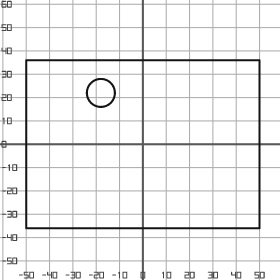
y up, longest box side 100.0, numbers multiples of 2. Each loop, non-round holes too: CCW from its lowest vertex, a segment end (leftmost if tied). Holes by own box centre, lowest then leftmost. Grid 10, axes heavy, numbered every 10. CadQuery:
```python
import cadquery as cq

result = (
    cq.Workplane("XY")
    .moveTo(-50.0, -36.0)
    .lineTo(50.0, -36.0)
    .lineTo(50.0, 36.0)
    .lineTo(-50.0, 36.0)
    .close()
    .moveTo(-18.0, 22.0)
    .circle(6.0)
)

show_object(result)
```